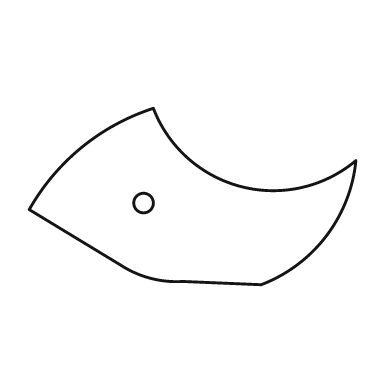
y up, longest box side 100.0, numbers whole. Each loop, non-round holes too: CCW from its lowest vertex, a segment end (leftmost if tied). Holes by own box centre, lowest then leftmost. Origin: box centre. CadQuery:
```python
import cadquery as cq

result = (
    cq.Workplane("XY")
    .moveTo(21.0, -27.0)
    .threePointArc((41.0, -12.0), (50.0, 11.0))
    .threePointArc((15.0, 3.0), (-12.0, 27.0))
    .threePointArc((-34.0, 15.0), (-50.0, -4.0))
    .lineTo(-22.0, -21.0)
    .threePointArc((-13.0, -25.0), (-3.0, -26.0))
    .close()
    .moveTo(-15.0, -2.0)
    .circle(3.0)
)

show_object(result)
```